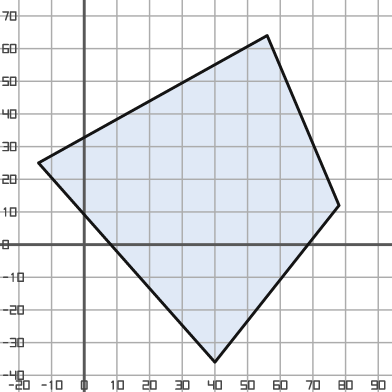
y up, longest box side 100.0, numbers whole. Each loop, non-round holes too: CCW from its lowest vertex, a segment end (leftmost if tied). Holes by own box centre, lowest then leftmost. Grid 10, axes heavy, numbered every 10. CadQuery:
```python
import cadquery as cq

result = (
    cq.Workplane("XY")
    .moveTo(40.0, -36.0)
    .lineTo(78.0, 12.0)
    .lineTo(56.0, 64.0)
    .lineTo(-14.0, 25.0)
    .close()
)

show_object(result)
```